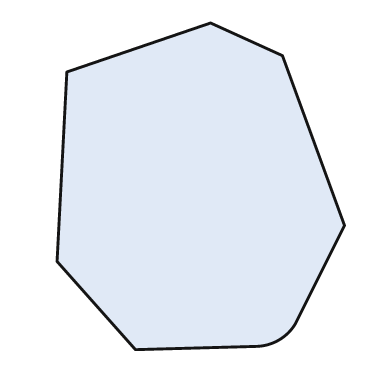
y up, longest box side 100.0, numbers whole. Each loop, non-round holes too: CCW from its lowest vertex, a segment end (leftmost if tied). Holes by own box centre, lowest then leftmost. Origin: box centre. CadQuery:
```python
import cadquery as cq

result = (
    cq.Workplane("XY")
    .moveTo(-20.0, -50.0)
    .lineTo(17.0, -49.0)
    .threePointArc((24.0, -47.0), (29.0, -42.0))
    .lineTo(44.0, -12.0)
    .lineTo(25.0, 40.0)
    .lineTo(3.0, 50.0)
    .lineTo(-41.0, 35.0)
    .lineTo(-44.0, -23.0)
    .close()
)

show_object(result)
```